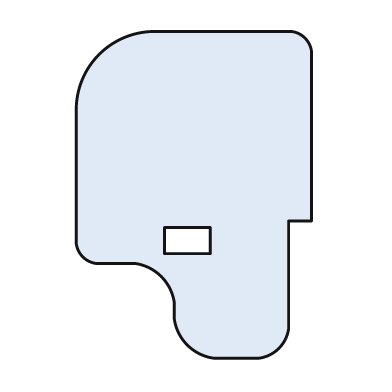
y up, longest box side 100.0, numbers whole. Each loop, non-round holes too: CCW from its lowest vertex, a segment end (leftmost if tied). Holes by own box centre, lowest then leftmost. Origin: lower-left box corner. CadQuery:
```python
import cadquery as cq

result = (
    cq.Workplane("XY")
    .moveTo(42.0, 0.0)
    .lineTo(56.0, 0.0)
    .threePointArc((62.0, 3.0), (65.0, 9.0))
    .lineTo(65.0, 42.0)
    .lineTo(72.0, 42.0)
    .lineTo(72.0, 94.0)
    .threePointArc((70.0, 98.0), (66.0, 100.0))
    .lineTo(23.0, 100.0)
    .threePointArc((7.0, 93.0), (0.0, 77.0))
    .lineTo(0.0, 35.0)
    .threePointArc((2.0, 31.0), (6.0, 29.0))
    .lineTo(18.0, 29.0)
    .threePointArc((26.0, 25.0), (30.0, 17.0))
    .lineTo(30.0, 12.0)
    .threePointArc((34.0, 4.0), (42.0, 0.0))
    .close()
    .moveTo(27.0, 32.0)
    .lineTo(41.0, 32.0)
    .lineTo(41.0, 40.0)
    .lineTo(27.0, 40.0)
    .close()
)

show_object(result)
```